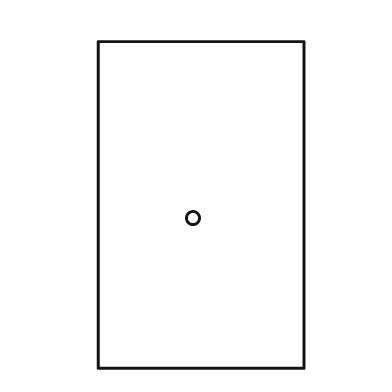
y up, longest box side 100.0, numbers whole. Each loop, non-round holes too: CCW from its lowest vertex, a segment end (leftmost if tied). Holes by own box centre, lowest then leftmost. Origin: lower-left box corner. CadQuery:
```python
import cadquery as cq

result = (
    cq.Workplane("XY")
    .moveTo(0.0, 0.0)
    .lineTo(63.0, 0.0)
    .lineTo(63.0, 100.0)
    .lineTo(0.0, 100.0)
    .close()
    .moveTo(29.0, 46.0)
    .circle(2.0)
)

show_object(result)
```